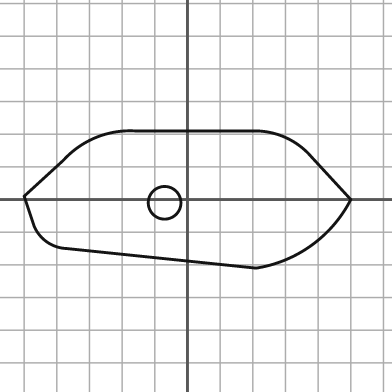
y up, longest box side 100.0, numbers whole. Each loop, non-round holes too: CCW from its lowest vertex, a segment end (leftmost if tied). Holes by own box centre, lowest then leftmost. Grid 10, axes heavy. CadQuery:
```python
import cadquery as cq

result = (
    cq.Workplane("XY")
    .moveTo(21.0, -21.0)
    .threePointArc((38.0, -14.0), (50.0, 0.0))
    .lineTo(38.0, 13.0)
    .threePointArc((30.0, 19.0), (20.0, 21.0))
    .lineTo(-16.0, 21.0)
    .threePointArc((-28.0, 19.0), (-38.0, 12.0))
    .lineTo(-50.0, 1.0)
    .lineTo(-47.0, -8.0)
    .threePointArc((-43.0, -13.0), (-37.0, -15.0))
    .close()
    .moveTo(-7.0, -1.0)
    .circle(5.0)
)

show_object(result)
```